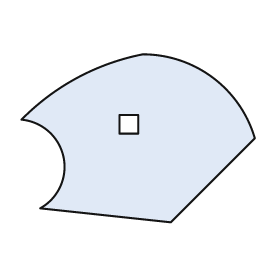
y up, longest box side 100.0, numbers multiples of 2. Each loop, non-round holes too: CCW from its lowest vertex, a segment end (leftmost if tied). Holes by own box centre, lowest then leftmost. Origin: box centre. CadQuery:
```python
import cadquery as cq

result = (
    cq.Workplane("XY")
    .moveTo(14.0, -36.0)
    .lineTo(50.0, 0.0)
    .threePointArc((32.0, 26.0), (2.0, 36.0))
    .threePointArc((-26.0, 26.0), (-50.0, 8.0))
    .threePointArc((-32.0, -8.0), (-42.0, -30.0))
    .close()
    .moveTo(-8.0, 2.0)
    .lineTo(0.0, 2.0)
    .lineTo(0.0, 10.0)
    .lineTo(-8.0, 10.0)
    .close()
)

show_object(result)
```